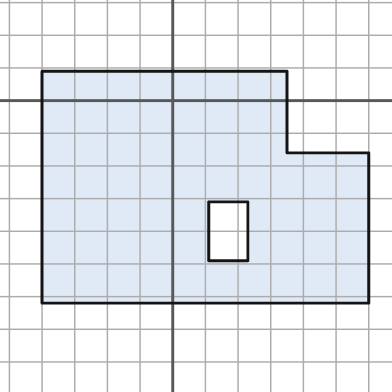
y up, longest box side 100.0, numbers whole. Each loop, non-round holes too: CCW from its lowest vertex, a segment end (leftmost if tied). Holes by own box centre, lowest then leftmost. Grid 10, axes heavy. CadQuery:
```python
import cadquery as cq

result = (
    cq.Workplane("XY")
    .moveTo(-40.0, -62.0)
    .lineTo(60.0, -62.0)
    .lineTo(60.0, -16.0)
    .lineTo(35.0, -16.0)
    .lineTo(35.0, 9.0)
    .lineTo(-40.0, 9.0)
    .close()
    .moveTo(11.0, -49.0)
    .lineTo(23.0, -49.0)
    .lineTo(23.0, -31.0)
    .lineTo(11.0, -31.0)
    .close()
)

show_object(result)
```